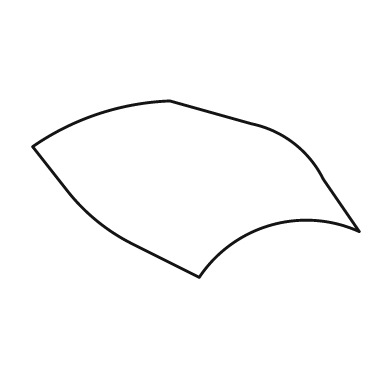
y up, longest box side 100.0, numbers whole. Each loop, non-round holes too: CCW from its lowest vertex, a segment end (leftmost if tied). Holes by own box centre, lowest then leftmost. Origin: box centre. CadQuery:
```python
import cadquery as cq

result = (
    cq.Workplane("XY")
    .moveTo(1.0, -27.0)
    .threePointArc((23.0, -11.0), (50.0, -13.0))
    .lineTo(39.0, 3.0)
    .threePointArc((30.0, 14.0), (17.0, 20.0))
    .lineTo(-8.0, 27.0)
    .threePointArc((-30.0, 23.0), (-50.0, 13.0))
    .lineTo(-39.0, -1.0)
    .threePointArc((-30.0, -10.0), (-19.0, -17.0))
    .close()
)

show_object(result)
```